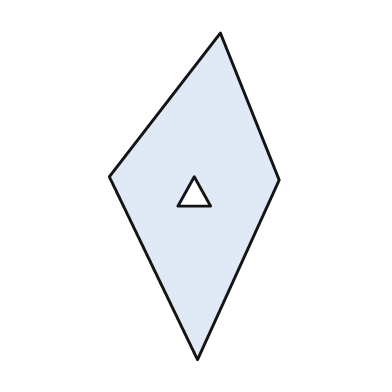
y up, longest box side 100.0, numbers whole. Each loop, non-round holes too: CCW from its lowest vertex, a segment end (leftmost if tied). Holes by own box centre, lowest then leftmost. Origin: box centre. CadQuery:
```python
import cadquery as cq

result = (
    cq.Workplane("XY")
    .moveTo(1.0, -50.0)
    .lineTo(26.0, 5.0)
    .lineTo(8.0, 50.0)
    .lineTo(-26.0, 6.0)
    .close()
    .moveTo(-5.0, -3.0)
    .lineTo(5.0, -3.0)
    .lineTo(0.0, 6.0)
    .close()
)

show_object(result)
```